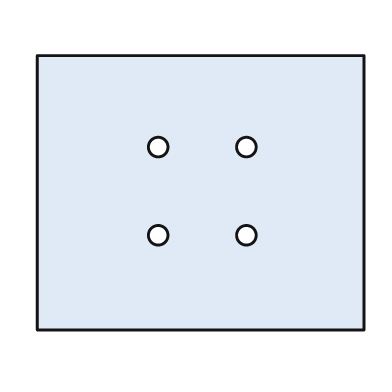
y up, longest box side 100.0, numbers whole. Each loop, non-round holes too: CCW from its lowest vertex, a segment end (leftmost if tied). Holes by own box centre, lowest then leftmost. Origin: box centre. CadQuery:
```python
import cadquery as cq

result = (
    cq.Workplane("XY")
    .moveTo(-50.0, -42.0)
    .lineTo(50.0, -42.0)
    .lineTo(50.0, 42.0)
    .lineTo(-50.0, 42.0)
    .close()
    .moveTo(-13.0, -13.0)
    .circle(3.0)
    .moveTo(14.0, -13.0)
    .circle(3.0)
    .moveTo(-13.0, 14.0)
    .circle(3.0)
    .moveTo(14.0, 14.0)
    .circle(3.0)
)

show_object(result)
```